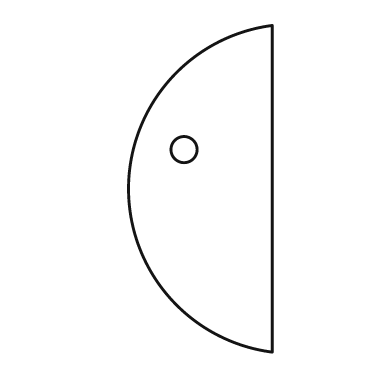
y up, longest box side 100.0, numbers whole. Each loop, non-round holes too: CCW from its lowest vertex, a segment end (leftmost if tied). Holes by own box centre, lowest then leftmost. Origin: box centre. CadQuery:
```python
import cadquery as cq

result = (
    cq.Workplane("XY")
    .moveTo(22.0, -50.0)
    .lineTo(22.0, 50.0)
    .threePointArc((-22.0, 0.0), (22.0, -50.0))
    .close()
    .moveTo(-5.0, 12.0)
    .circle(4.0)
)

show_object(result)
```